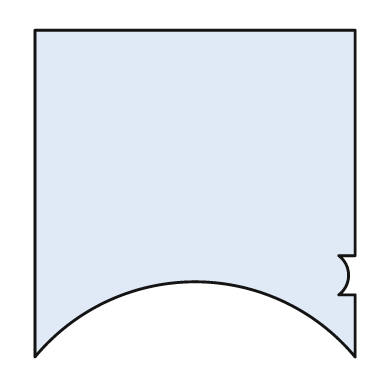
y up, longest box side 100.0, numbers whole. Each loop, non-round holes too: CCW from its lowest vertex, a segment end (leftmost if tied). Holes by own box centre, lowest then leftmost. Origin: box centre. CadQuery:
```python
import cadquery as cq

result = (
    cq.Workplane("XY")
    .moveTo(-49.0, -50.0)
    .threePointArc((0.0, -27.0), (49.0, -50.0))
    .lineTo(49.0, -31.0)
    .lineTo(44.0, -31.0)
    .threePointArc((47.0, -25.0), (44.0, -19.0))
    .lineTo(49.0, -19.0)
    .lineTo(49.0, 50.0)
    .lineTo(-49.0, 50.0)
    .close()
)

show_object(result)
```